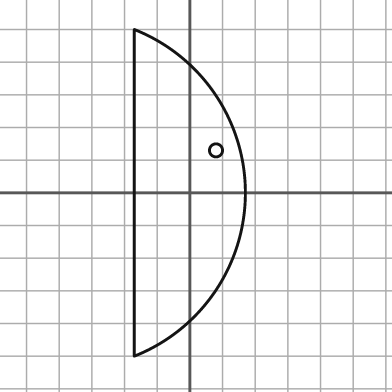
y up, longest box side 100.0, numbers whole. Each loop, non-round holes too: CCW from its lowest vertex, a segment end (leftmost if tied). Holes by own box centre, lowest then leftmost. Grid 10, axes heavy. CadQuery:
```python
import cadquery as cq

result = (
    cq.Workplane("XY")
    .moveTo(-17.0, -50.0)
    .threePointArc((17.0, 0.0), (-17.0, 50.0))
    .close()
    .moveTo(8.0, 13.0)
    .circle(2.0)
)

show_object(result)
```